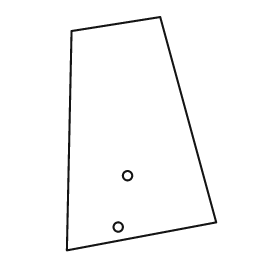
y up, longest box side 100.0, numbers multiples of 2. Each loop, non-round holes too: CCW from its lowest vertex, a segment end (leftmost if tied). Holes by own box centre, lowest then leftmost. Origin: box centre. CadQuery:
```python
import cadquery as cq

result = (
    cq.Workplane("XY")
    .moveTo(-32.0, -50.0)
    .lineTo(32.0, -38.0)
    .lineTo(8.0, 50.0)
    .lineTo(-30.0, 44.0)
    .close()
    .moveTo(-10.0, -40.0)
    .circle(2.0)
    .moveTo(-6.0, -18.0)
    .circle(2.0)
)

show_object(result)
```